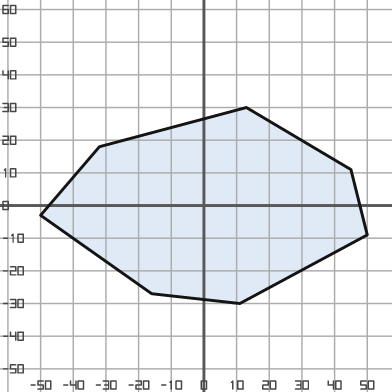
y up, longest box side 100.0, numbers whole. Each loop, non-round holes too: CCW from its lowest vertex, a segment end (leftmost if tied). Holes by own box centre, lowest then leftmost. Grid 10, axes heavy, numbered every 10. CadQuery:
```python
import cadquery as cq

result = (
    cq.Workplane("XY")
    .moveTo(11.0, -30.0)
    .lineTo(50.0, -9.0)
    .lineTo(45.0, 11.0)
    .lineTo(13.0, 30.0)
    .lineTo(-32.0, 18.0)
    .lineTo(-50.0, -3.0)
    .lineTo(-16.0, -27.0)
    .close()
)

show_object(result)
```